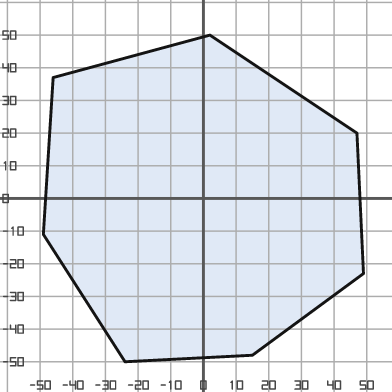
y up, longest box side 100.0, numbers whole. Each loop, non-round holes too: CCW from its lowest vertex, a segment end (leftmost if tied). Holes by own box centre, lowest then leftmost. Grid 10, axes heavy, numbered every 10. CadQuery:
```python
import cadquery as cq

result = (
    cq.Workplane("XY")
    .moveTo(-24.0, -50.0)
    .lineTo(15.0, -48.0)
    .lineTo(49.0, -23.0)
    .lineTo(47.0, 20.0)
    .lineTo(2.0, 50.0)
    .lineTo(-46.0, 37.0)
    .lineTo(-49.0, -11.0)
    .close()
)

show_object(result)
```